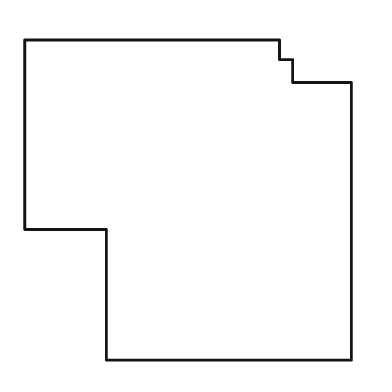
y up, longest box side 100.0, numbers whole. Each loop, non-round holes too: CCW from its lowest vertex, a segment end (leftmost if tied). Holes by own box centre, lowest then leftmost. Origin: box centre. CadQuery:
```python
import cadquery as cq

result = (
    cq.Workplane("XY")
    .moveTo(-25.0, -49.0)
    .lineTo(50.0, -49.0)
    .lineTo(50.0, 36.0)
    .lineTo(32.0, 36.0)
    .lineTo(32.0, 43.0)
    .lineTo(28.0, 43.0)
    .lineTo(28.0, 49.0)
    .lineTo(-50.0, 49.0)
    .lineTo(-50.0, -9.0)
    .lineTo(-25.0, -9.0)
    .close()
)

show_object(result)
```